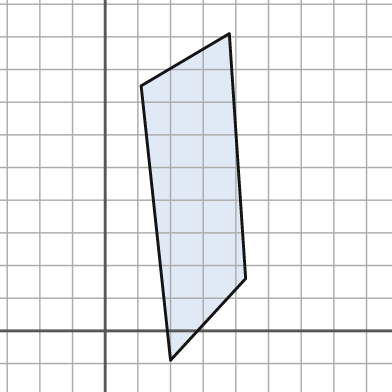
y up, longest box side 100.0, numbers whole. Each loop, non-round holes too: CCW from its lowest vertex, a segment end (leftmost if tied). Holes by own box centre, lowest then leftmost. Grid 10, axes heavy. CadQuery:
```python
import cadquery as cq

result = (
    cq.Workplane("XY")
    .moveTo(20.0, -9.0)
    .lineTo(43.0, 16.0)
    .lineTo(38.0, 91.0)
    .lineTo(11.0, 75.0)
    .close()
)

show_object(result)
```